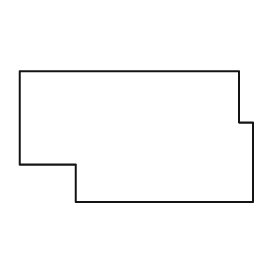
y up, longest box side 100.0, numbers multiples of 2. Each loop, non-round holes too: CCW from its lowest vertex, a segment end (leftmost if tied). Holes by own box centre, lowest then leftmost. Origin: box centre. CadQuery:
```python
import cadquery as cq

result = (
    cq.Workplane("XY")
    .moveTo(-26.0, -28.0)
    .lineTo(50.0, -28.0)
    .lineTo(50.0, 6.0)
    .lineTo(44.0, 6.0)
    .lineTo(44.0, 28.0)
    .lineTo(-50.0, 28.0)
    .lineTo(-50.0, -12.0)
    .lineTo(-26.0, -12.0)
    .close()
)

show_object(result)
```